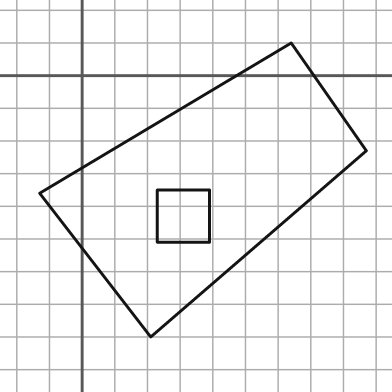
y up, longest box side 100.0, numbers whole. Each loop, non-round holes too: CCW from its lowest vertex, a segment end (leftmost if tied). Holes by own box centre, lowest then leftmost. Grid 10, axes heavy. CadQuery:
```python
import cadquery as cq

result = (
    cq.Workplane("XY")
    .moveTo(21.0, -80.0)
    .lineTo(87.0, -23.0)
    .lineTo(64.0, 10.0)
    .lineTo(-13.0, -36.0)
    .close()
    .moveTo(23.0, -51.0)
    .lineTo(39.0, -51.0)
    .lineTo(39.0, -35.0)
    .lineTo(23.0, -35.0)
    .close()
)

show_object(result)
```